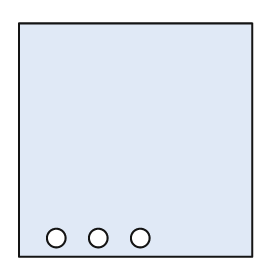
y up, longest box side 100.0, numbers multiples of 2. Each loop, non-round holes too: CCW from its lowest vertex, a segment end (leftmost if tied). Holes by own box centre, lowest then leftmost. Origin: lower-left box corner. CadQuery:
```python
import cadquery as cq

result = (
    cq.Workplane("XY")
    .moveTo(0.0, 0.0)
    .lineTo(100.0, 0.0)
    .lineTo(100.0, 100.0)
    .lineTo(0.0, 100.0)
    .close()
    .moveTo(16.0, 8.0)
    .circle(4.0)
    .moveTo(34.0, 8.0)
    .circle(4.0)
    .moveTo(52.0, 8.0)
    .circle(4.0)
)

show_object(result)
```